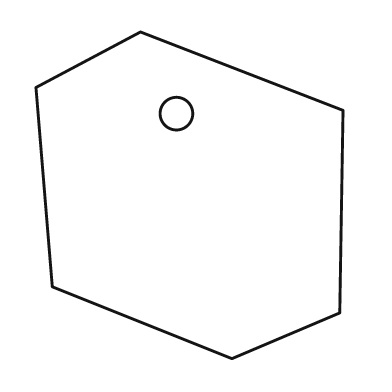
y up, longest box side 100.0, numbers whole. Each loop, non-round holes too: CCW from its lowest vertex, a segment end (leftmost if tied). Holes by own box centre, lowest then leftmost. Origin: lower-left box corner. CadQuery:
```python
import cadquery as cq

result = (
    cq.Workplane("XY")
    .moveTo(60.0, 0.0)
    .lineTo(93.0, 14.0)
    .lineTo(94.0, 76.0)
    .lineTo(32.0, 100.0)
    .lineTo(0.0, 83.0)
    .lineTo(5.0, 22.0)
    .close()
    .moveTo(43.0, 75.0)
    .circle(5.0)
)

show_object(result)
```